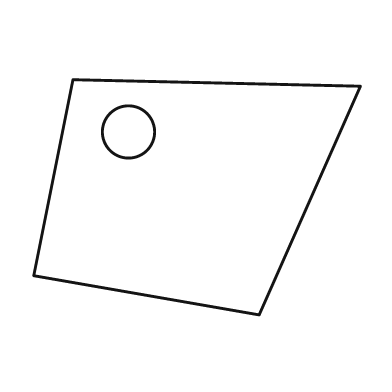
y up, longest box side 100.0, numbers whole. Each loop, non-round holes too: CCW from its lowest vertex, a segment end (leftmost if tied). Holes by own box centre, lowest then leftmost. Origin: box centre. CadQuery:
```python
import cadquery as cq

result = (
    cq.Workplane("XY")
    .moveTo(19.0, -36.0)
    .lineTo(50.0, 34.0)
    .lineTo(-38.0, 36.0)
    .lineTo(-50.0, -24.0)
    .close()
    .moveTo(-21.0, 20.0)
    .circle(8.0)
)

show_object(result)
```